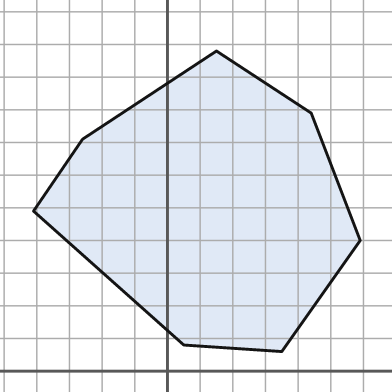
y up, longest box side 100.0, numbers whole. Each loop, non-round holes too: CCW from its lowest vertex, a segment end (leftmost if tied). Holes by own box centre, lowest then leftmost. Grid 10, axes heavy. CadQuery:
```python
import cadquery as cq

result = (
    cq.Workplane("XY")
    .moveTo(35.0, 6.0)
    .lineTo(59.0, 40.0)
    .lineTo(44.0, 79.0)
    .lineTo(15.0, 98.0)
    .lineTo(-26.0, 71.0)
    .lineTo(-41.0, 49.0)
    .lineTo(5.0, 8.0)
    .close()
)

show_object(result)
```